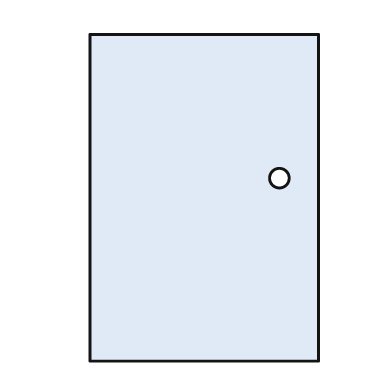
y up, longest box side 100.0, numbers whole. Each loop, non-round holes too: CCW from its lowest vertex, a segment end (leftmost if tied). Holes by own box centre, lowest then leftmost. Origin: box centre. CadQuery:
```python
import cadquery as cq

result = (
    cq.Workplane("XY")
    .moveTo(-35.0, -50.0)
    .lineTo(35.0, -50.0)
    .lineTo(35.0, 50.0)
    .lineTo(-35.0, 50.0)
    .close()
    .moveTo(23.0, 6.0)
    .circle(3.0)
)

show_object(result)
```